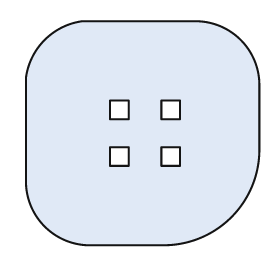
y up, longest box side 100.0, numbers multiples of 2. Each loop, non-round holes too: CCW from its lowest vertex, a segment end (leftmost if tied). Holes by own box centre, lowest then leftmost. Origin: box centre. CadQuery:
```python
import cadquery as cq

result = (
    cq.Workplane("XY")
    .moveTo(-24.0, -48.0)
    .lineTo(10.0, -48.0)
    .threePointArc((38.0, -36.0), (50.0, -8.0))
    .lineTo(50.0, 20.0)
    .threePointArc((42.0, 40.0), (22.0, 48.0))
    .lineTo(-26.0, 48.0)
    .threePointArc((-42.0, 40.0), (-50.0, 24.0))
    .lineTo(-50.0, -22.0)
    .threePointArc((-42.0, -40.0), (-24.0, -48.0))
    .close()
    .moveTo(-14.0, -14.0)
    .lineTo(-6.0, -14.0)
    .lineTo(-6.0, -6.0)
    .lineTo(-14.0, -6.0)
    .close()
    .moveTo(8.0, -14.0)
    .lineTo(16.0, -14.0)
    .lineTo(16.0, -6.0)
    .lineTo(8.0, -6.0)
    .close()
    .moveTo(-14.0, 6.0)
    .lineTo(-6.0, 6.0)
    .lineTo(-6.0, 14.0)
    .lineTo(-14.0, 14.0)
    .close()
    .moveTo(8.0, 6.0)
    .lineTo(16.0, 6.0)
    .lineTo(16.0, 14.0)
    .lineTo(8.0, 14.0)
    .close()
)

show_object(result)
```